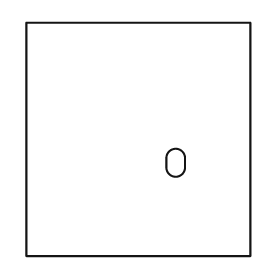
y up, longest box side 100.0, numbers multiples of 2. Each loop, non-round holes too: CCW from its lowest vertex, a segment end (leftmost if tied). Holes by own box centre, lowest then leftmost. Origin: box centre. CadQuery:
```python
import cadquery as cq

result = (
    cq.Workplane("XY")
    .moveTo(-48.0, -50.0)
    .lineTo(48.0, -50.0)
    .lineTo(48.0, 50.0)
    .lineTo(-48.0, 50.0)
    .close()
    .moveTo(12.0, -12.0)
    .threePointArc((16.0, -16.0), (20.0, -12.0))
    .lineTo(20.0, -8.0)
    .threePointArc((16.0, -4.0), (12.0, -8.0))
    .close()
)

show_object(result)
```